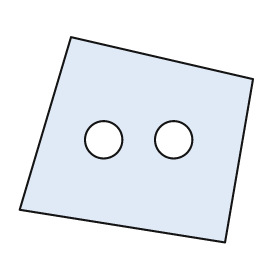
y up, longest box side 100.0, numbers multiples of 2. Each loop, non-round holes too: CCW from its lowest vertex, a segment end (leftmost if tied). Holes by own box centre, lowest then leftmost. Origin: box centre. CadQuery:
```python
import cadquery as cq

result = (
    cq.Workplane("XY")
    .moveTo(38.0, -44.0)
    .lineTo(50.0, 26.0)
    .lineTo(-28.0, 44.0)
    .lineTo(-50.0, -30.0)
    .close()
    .moveTo(-14.0, 0.0)
    .circle(8.0)
    .moveTo(16.0, 0.0)
    .circle(8.0)
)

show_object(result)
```